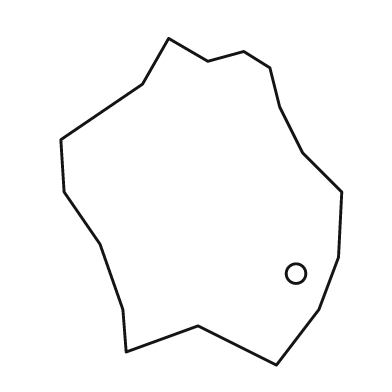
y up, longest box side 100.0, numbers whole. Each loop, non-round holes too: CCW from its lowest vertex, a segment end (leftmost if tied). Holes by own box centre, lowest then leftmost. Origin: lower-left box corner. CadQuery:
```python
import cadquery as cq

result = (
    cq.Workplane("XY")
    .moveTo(66.0, 0.0)
    .lineTo(79.0, 17.0)
    .lineTo(85.0, 33.0)
    .lineTo(86.0, 53.0)
    .lineTo(74.0, 65.0)
    .lineTo(67.0, 79.0)
    .lineTo(64.0, 91.0)
    .lineTo(56.0, 96.0)
    .lineTo(45.0, 93.0)
    .lineTo(33.0, 100.0)
    .lineTo(25.0, 86.0)
    .lineTo(0.0, 69.0)
    .lineTo(1.0, 53.0)
    .lineTo(12.0, 37.0)
    .lineTo(19.0, 17.0)
    .lineTo(20.0, 4.0)
    .lineTo(42.0, 12.0)
    .close()
    .moveTo(72.0, 28.0)
    .circle(3.0)
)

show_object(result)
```